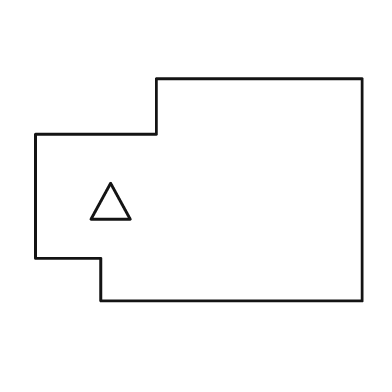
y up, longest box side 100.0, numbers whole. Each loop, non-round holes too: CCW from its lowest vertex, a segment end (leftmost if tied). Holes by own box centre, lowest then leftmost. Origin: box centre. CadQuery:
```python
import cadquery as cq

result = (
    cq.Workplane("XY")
    .moveTo(-30.0, -34.0)
    .lineTo(50.0, -34.0)
    .lineTo(50.0, 34.0)
    .lineTo(-13.0, 34.0)
    .lineTo(-13.0, 17.0)
    .lineTo(-50.0, 17.0)
    .lineTo(-50.0, -21.0)
    .lineTo(-30.0, -21.0)
    .close()
    .moveTo(-33.0, -9.0)
    .lineTo(-21.0, -9.0)
    .lineTo(-27.0, 2.0)
    .close()
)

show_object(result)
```